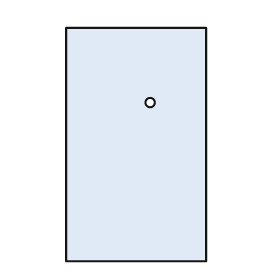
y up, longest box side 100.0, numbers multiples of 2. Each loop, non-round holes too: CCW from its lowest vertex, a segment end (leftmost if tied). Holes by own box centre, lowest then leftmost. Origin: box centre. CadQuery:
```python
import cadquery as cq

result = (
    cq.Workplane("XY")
    .moveTo(-30.0, -50.0)
    .lineTo(30.0, -50.0)
    .lineTo(30.0, 50.0)
    .lineTo(-30.0, 50.0)
    .close()
    .moveTo(6.0, 18.0)
    .circle(2.0)
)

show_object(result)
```